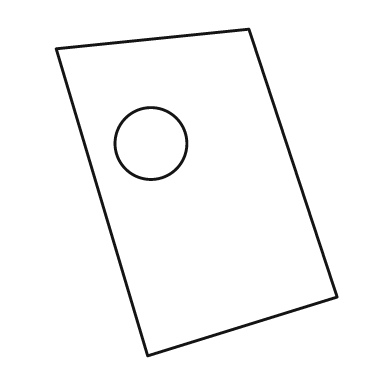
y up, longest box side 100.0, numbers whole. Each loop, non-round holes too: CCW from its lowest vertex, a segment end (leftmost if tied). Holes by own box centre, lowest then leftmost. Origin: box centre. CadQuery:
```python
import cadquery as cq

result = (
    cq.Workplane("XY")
    .moveTo(-15.0, -50.0)
    .lineTo(43.0, -32.0)
    .lineTo(16.0, 50.0)
    .lineTo(-43.0, 44.0)
    .close()
    .moveTo(-14.0, 15.0)
    .circle(11.0)
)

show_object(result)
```